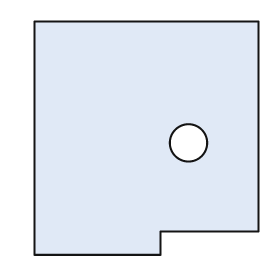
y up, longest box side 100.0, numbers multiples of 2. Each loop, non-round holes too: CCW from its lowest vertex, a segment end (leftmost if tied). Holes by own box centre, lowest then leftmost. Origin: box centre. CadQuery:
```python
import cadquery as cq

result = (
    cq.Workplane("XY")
    .moveTo(-48.0, -50.0)
    .lineTo(6.0, -50.0)
    .lineTo(6.0, -40.0)
    .lineTo(48.0, -40.0)
    .lineTo(48.0, 50.0)
    .lineTo(-48.0, 50.0)
    .close()
    .moveTo(18.0, -2.0)
    .circle(8.0)
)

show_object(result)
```